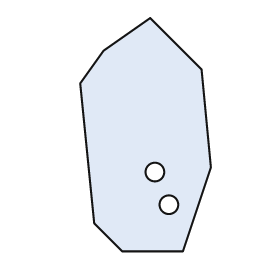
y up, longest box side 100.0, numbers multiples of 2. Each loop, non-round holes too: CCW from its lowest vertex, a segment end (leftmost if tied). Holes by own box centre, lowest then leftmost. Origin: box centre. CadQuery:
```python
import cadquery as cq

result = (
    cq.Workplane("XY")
    .moveTo(-10.0, -50.0)
    .lineTo(16.0, -50.0)
    .lineTo(28.0, -14.0)
    .lineTo(24.0, 28.0)
    .lineTo(2.0, 50.0)
    .lineTo(-18.0, 36.0)
    .lineTo(-28.0, 22.0)
    .lineTo(-22.0, -38.0)
    .close()
    .moveTo(10.0, -30.0)
    .circle(4.0)
    .moveTo(4.0, -16.0)
    .circle(4.0)
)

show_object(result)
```